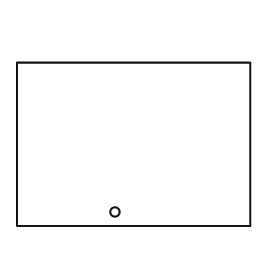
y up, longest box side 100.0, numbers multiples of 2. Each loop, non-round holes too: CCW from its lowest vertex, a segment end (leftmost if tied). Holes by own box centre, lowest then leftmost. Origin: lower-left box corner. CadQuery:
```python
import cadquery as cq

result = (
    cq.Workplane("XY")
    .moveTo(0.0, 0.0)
    .lineTo(100.0, 0.0)
    .lineTo(100.0, 70.0)
    .lineTo(0.0, 70.0)
    .close()
    .moveTo(42.0, 6.0)
    .circle(2.0)
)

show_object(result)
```